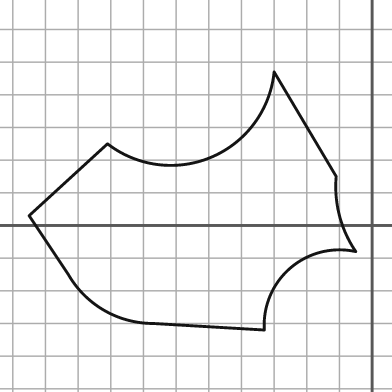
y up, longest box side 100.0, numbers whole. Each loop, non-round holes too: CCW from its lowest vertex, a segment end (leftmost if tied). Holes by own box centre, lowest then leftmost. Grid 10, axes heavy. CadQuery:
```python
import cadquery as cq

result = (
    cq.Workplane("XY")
    .moveTo(-33.0, -32.0)
    .threePointArc((-25.0, -13.0), (-5.0, -8.0))
    .threePointArc((-10.0, 3.0), (-11.0, 15.0))
    .lineTo(-30.0, 47.0)
    .threePointArc((-49.0, 21.0), (-81.0, 25.0))
    .lineTo(-105.0, 3.0)
    .lineTo(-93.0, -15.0)
    .threePointArc((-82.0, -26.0), (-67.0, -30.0))
    .close()
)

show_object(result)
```